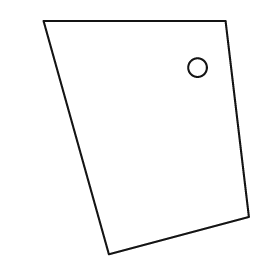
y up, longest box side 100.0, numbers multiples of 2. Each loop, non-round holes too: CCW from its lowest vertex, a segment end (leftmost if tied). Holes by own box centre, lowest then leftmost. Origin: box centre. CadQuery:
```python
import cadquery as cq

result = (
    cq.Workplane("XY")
    .moveTo(-16.0, -50.0)
    .lineTo(44.0, -34.0)
    .lineTo(34.0, 50.0)
    .lineTo(-44.0, 50.0)
    .close()
    .moveTo(22.0, 30.0)
    .circle(4.0)
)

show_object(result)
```